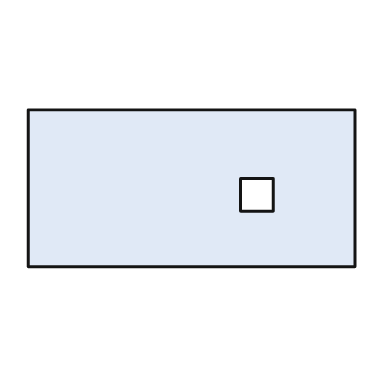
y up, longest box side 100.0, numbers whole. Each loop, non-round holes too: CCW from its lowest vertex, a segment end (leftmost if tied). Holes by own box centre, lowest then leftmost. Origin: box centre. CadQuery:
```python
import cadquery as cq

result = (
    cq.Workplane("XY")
    .moveTo(-50.0, -24.0)
    .lineTo(50.0, -24.0)
    .lineTo(50.0, 24.0)
    .lineTo(-50.0, 24.0)
    .close()
    .moveTo(15.0, -7.0)
    .lineTo(25.0, -7.0)
    .lineTo(25.0, 3.0)
    .lineTo(15.0, 3.0)
    .close()
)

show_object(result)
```